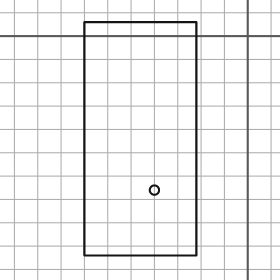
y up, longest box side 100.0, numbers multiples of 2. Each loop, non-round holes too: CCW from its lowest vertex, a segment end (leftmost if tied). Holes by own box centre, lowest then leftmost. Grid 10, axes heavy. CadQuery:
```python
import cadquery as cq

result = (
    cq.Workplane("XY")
    .moveTo(-70.0, -94.0)
    .lineTo(-22.0, -94.0)
    .lineTo(-22.0, 6.0)
    .lineTo(-70.0, 6.0)
    .close()
    .moveTo(-40.0, -66.0)
    .circle(2.0)
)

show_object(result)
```